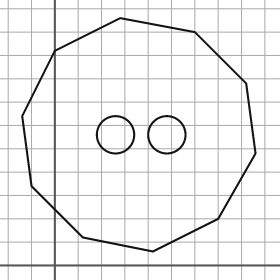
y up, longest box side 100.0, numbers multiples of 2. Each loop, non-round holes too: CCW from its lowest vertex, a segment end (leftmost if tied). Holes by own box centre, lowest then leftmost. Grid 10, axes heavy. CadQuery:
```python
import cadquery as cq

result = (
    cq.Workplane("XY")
    .moveTo(42.0, 6.0)
    .lineTo(70.0, 20.0)
    .lineTo(86.0, 48.0)
    .lineTo(82.0, 78.0)
    .lineTo(60.0, 100.0)
    .lineTo(28.0, 106.0)
    .lineTo(0.0, 92.0)
    .lineTo(-14.0, 64.0)
    .lineTo(-10.0, 34.0)
    .lineTo(12.0, 12.0)
    .close()
    .moveTo(26.0, 56.0)
    .circle(8.0)
    .moveTo(48.0, 56.0)
    .circle(8.0)
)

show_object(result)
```